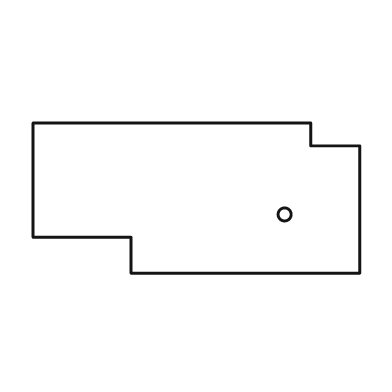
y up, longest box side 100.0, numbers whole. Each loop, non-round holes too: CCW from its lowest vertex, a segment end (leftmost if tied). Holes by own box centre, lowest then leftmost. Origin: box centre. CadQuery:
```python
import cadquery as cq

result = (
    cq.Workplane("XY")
    .moveTo(-20.0, -23.0)
    .lineTo(50.0, -23.0)
    .lineTo(50.0, 16.0)
    .lineTo(35.0, 16.0)
    .lineTo(35.0, 23.0)
    .lineTo(-50.0, 23.0)
    .lineTo(-50.0, -12.0)
    .lineTo(-20.0, -12.0)
    .close()
    .moveTo(27.0, -5.0)
    .circle(2.0)
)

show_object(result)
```